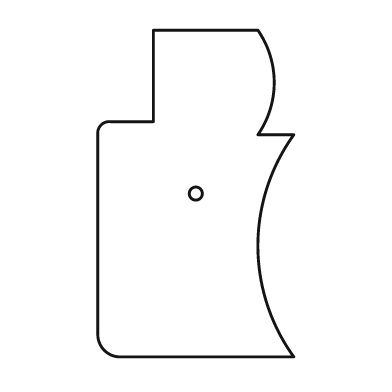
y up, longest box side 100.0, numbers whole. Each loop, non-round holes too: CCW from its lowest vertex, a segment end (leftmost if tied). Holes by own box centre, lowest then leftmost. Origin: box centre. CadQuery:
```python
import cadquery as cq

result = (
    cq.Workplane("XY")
    .moveTo(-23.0, -50.0)
    .lineTo(30.0, -50.0)
    .threePointArc((19.0, -16.0), (30.0, 18.0))
    .lineTo(19.0, 18.0)
    .threePointArc((24.0, 34.0), (19.0, 50.0))
    .lineTo(-13.0, 50.0)
    .lineTo(-13.0, 22.0)
    .lineTo(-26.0, 22.0)
    .threePointArc((-29.0, 21.0), (-30.0, 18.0))
    .lineTo(-30.0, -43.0)
    .threePointArc((-28.0, -48.0), (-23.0, -50.0))
    .close()
    .moveTo(0.0, 0.0)
    .circle(2.0)
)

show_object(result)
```